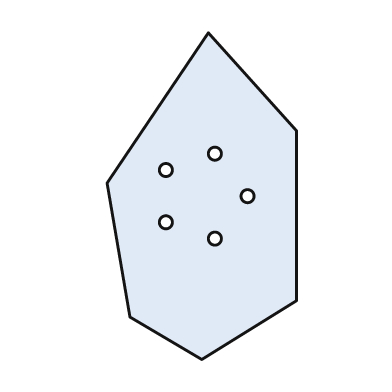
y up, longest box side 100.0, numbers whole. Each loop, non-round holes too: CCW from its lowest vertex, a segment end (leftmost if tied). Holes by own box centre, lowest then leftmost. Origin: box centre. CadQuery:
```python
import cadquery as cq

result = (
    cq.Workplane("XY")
    .moveTo(0.0, -50.0)
    .lineTo(29.0, -32.0)
    .lineTo(29.0, 20.0)
    .lineTo(2.0, 50.0)
    .lineTo(-29.0, 4.0)
    .lineTo(-22.0, -37.0)
    .close()
    .moveTo(4.0, -13.0)
    .circle(2.0)
    .moveTo(-11.0, -8.0)
    .circle(2.0)
    .moveTo(14.0, 0.0)
    .circle(2.0)
    .moveTo(-11.0, 8.0)
    .circle(2.0)
    .moveTo(4.0, 13.0)
    .circle(2.0)
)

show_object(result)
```